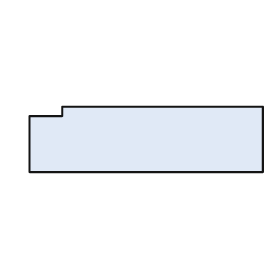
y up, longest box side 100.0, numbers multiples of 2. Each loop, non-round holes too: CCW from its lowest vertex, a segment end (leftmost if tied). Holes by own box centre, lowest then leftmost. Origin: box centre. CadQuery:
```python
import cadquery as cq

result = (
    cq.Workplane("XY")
    .moveTo(-50.0, -14.0)
    .lineTo(50.0, -14.0)
    .lineTo(50.0, 14.0)
    .lineTo(-36.0, 14.0)
    .lineTo(-36.0, 10.0)
    .lineTo(-50.0, 10.0)
    .close()
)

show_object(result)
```